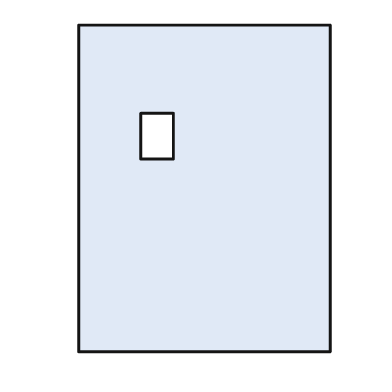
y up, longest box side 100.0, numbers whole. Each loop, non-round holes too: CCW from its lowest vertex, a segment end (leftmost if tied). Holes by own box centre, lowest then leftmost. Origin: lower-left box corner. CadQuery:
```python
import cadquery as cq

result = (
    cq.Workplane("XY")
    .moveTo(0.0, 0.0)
    .lineTo(77.0, 0.0)
    .lineTo(77.0, 100.0)
    .lineTo(0.0, 100.0)
    .close()
    .moveTo(19.0, 59.0)
    .lineTo(29.0, 59.0)
    .lineTo(29.0, 73.0)
    .lineTo(19.0, 73.0)
    .close()
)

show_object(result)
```